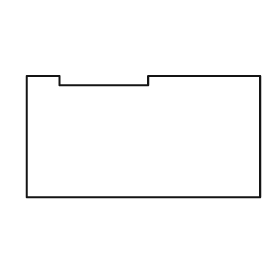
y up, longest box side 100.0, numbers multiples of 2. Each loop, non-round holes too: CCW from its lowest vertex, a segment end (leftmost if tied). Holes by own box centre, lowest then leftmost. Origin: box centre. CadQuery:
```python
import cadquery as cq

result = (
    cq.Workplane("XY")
    .moveTo(-50.0, -26.0)
    .lineTo(50.0, -26.0)
    .lineTo(50.0, 26.0)
    .lineTo(2.0, 26.0)
    .lineTo(2.0, 22.0)
    .lineTo(-36.0, 22.0)
    .lineTo(-36.0, 26.0)
    .lineTo(-50.0, 26.0)
    .close()
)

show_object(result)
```